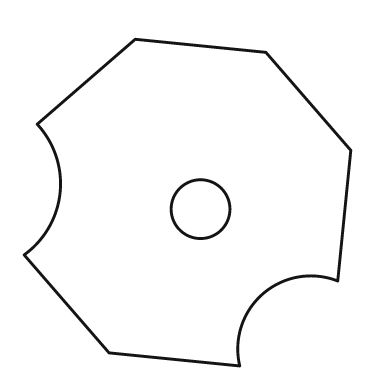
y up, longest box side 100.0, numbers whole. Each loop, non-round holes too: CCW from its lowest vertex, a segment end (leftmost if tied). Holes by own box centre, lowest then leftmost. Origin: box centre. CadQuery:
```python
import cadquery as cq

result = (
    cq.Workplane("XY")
    .moveTo(16.0, -50.0)
    .threePointArc((23.0, -28.0), (46.0, -24.0))
    .lineTo(50.0, 16.0)
    .lineTo(24.0, 46.0)
    .lineTo(-16.0, 50.0)
    .lineTo(-46.0, 24.0)
    .threePointArc((-39.0, 3.0), (-50.0, -16.0))
    .lineTo(-24.0, -46.0)
    .close()
    .moveTo(4.0, -2.0)
    .circle(9.0)
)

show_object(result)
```